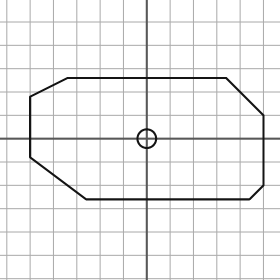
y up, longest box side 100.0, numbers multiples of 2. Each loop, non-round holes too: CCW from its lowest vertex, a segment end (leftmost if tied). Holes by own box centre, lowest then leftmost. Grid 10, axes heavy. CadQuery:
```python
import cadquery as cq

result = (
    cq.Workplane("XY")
    .moveTo(-26.0, -26.0)
    .lineTo(44.0, -26.0)
    .lineTo(50.0, -20.0)
    .lineTo(50.0, 10.0)
    .lineTo(34.0, 26.0)
    .lineTo(-34.0, 26.0)
    .lineTo(-50.0, 18.0)
    .lineTo(-50.0, -8.0)
    .close()
    .moveTo(0.0, 0.0)
    .circle(4.0)
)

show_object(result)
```